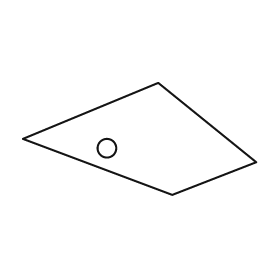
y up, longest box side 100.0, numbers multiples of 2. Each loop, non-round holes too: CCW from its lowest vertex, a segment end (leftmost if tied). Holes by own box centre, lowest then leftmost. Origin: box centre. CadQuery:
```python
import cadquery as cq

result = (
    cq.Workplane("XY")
    .moveTo(14.0, -24.0)
    .lineTo(50.0, -10.0)
    .lineTo(8.0, 24.0)
    .lineTo(-50.0, 0.0)
    .close()
    .moveTo(-14.0, -4.0)
    .circle(4.0)
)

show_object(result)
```